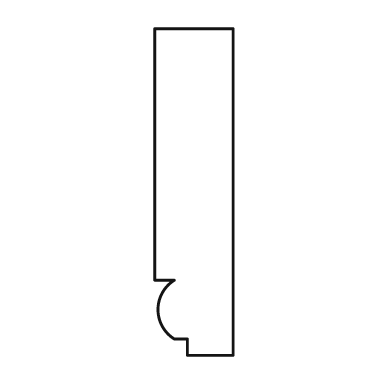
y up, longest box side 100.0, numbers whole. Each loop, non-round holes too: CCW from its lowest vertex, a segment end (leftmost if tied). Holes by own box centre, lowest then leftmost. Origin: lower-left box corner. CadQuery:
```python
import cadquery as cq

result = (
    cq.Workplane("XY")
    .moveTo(10.0, 0.0)
    .lineTo(24.0, 0.0)
    .lineTo(24.0, 100.0)
    .lineTo(0.0, 100.0)
    .lineTo(0.0, 23.0)
    .lineTo(6.0, 23.0)
    .threePointArc((1.0, 14.0), (6.0, 5.0))
    .lineTo(10.0, 5.0)
    .close()
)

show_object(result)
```